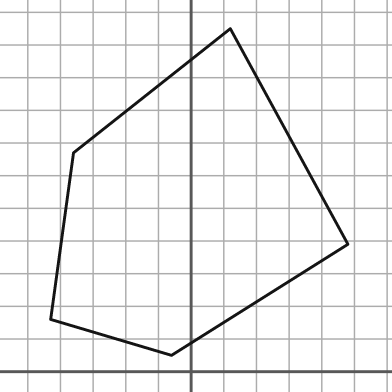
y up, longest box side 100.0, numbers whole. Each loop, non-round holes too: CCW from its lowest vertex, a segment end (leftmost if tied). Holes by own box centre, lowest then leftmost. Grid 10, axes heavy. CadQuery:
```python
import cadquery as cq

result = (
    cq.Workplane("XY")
    .moveTo(-6.0, 5.0)
    .lineTo(48.0, 39.0)
    .lineTo(12.0, 105.0)
    .lineTo(-36.0, 67.0)
    .lineTo(-43.0, 16.0)
    .close()
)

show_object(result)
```